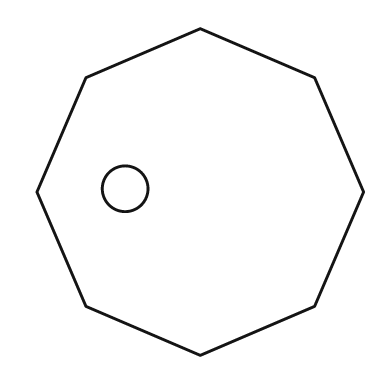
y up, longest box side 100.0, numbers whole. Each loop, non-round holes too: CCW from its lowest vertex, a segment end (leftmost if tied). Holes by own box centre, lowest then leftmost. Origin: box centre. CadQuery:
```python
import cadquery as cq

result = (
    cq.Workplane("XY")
    .moveTo(0.0, -50.0)
    .lineTo(35.0, -35.0)
    .lineTo(50.0, 0.0)
    .lineTo(35.0, 35.0)
    .lineTo(0.0, 50.0)
    .lineTo(-35.0, 35.0)
    .lineTo(-50.0, 0.0)
    .lineTo(-35.0, -35.0)
    .close()
    .moveTo(-23.0, 1.0)
    .circle(7.0)
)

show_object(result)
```